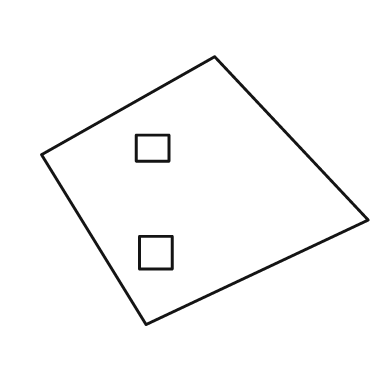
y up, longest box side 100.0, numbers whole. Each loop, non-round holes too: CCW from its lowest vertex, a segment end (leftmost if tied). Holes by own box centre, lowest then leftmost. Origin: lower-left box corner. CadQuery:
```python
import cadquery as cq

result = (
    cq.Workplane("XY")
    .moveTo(32.0, 0.0)
    .lineTo(100.0, 32.0)
    .lineTo(53.0, 82.0)
    .lineTo(0.0, 52.0)
    .close()
    .moveTo(30.0, 17.0)
    .lineTo(40.0, 17.0)
    .lineTo(40.0, 27.0)
    .lineTo(30.0, 27.0)
    .close()
    .moveTo(29.0, 50.0)
    .lineTo(39.0, 50.0)
    .lineTo(39.0, 58.0)
    .lineTo(29.0, 58.0)
    .close()
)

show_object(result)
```